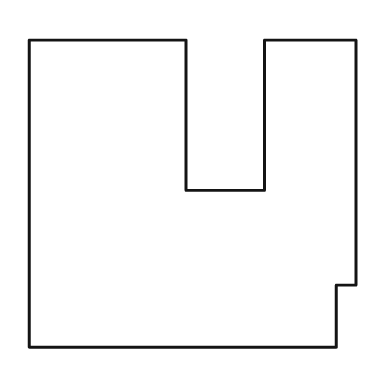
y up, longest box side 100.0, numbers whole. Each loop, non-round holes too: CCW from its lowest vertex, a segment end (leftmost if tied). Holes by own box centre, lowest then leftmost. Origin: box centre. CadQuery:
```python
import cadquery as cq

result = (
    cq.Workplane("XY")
    .moveTo(-50.0, -47.0)
    .lineTo(44.0, -47.0)
    .lineTo(44.0, -28.0)
    .lineTo(50.0, -28.0)
    .lineTo(50.0, 47.0)
    .lineTo(22.0, 47.0)
    .lineTo(22.0, 1.0)
    .lineTo(-2.0, 1.0)
    .lineTo(-2.0, 47.0)
    .lineTo(-50.0, 47.0)
    .close()
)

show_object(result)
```